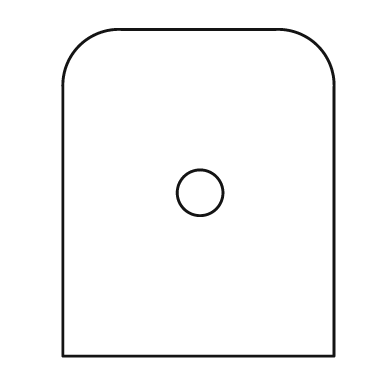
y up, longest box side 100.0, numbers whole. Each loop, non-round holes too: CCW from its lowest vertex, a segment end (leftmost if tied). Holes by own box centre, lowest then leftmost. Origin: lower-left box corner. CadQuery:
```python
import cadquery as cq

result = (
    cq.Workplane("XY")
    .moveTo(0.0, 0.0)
    .lineTo(83.0, 0.0)
    .lineTo(83.0, 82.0)
    .threePointArc((78.0, 95.0), (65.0, 100.0))
    .lineTo(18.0, 100.0)
    .threePointArc((5.0, 95.0), (0.0, 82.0))
    .close()
    .moveTo(42.0, 50.0)
    .circle(7.0)
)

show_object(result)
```